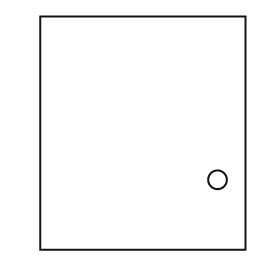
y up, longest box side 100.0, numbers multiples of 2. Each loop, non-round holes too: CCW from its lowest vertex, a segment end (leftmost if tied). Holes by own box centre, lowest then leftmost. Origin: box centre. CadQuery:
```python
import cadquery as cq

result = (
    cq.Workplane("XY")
    .moveTo(-44.0, -50.0)
    .lineTo(44.0, -50.0)
    .lineTo(44.0, 50.0)
    .lineTo(-44.0, 50.0)
    .close()
    .moveTo(32.0, -20.0)
    .circle(4.0)
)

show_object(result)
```